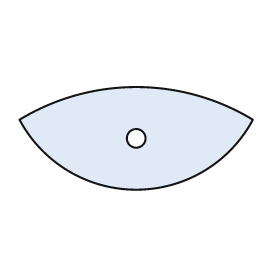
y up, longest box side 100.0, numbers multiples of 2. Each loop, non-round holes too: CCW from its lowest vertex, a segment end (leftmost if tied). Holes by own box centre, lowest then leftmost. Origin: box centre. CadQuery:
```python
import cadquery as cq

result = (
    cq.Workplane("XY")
    .moveTo(-50.0, 8.0)
    .threePointArc((0.0, -22.0), (50.0, 8.0))
    .threePointArc((0.0, 22.0), (-50.0, 8.0))
    .close()
    .moveTo(0.0, 0.0)
    .circle(4.0)
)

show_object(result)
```